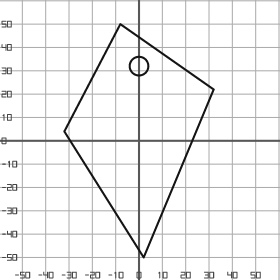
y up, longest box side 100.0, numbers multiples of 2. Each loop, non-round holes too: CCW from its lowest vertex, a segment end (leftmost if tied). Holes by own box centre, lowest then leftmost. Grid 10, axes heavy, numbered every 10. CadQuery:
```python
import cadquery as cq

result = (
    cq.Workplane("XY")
    .moveTo(2.0, -50.0)
    .lineTo(32.0, 22.0)
    .lineTo(-8.0, 50.0)
    .lineTo(-32.0, 4.0)
    .close()
    .moveTo(0.0, 32.0)
    .circle(4.0)
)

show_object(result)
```